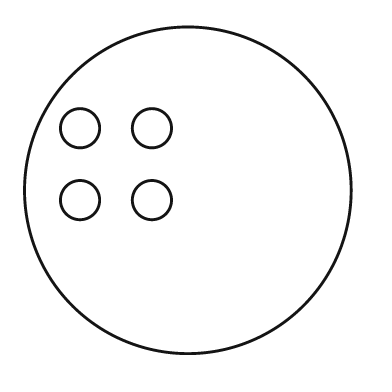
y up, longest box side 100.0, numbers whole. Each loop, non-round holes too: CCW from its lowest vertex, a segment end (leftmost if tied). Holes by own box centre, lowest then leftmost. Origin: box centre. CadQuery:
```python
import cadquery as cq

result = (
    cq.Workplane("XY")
    .moveTo(0.0, 0.0)
    .circle(50.0)
    .moveTo(-33.0, -3.0)
    .circle(6.0)
    .moveTo(-11.0, -3.0)
    .circle(6.0)
    .moveTo(-33.0, 19.0)
    .circle(6.0)
    .moveTo(-11.0, 19.0)
    .circle(6.0)
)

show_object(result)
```